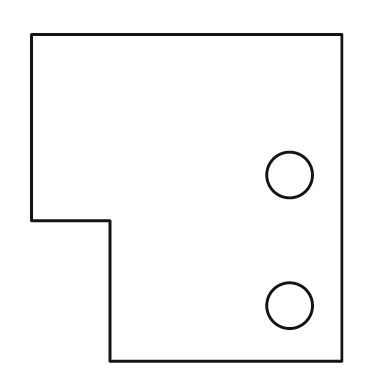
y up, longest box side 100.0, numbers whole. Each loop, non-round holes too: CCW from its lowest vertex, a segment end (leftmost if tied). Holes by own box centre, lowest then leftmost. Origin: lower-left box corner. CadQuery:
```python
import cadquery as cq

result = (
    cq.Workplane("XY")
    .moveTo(24.0, 0.0)
    .lineTo(95.0, 0.0)
    .lineTo(95.0, 100.0)
    .lineTo(0.0, 100.0)
    .lineTo(0.0, 43.0)
    .lineTo(24.0, 43.0)
    .close()
    .moveTo(79.0, 17.0)
    .circle(7.0)
    .moveTo(79.0, 57.0)
    .circle(7.0)
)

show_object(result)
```